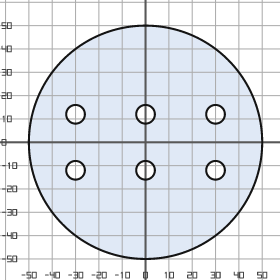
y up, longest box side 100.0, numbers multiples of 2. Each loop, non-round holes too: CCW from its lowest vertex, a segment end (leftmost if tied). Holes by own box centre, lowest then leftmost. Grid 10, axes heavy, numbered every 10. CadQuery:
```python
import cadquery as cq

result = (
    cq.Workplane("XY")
    .moveTo(0.0, 0.0)
    .circle(50.0)
    .moveTo(-30.0, -12.0)
    .circle(4.0)
    .moveTo(0.0, -12.0)
    .circle(4.0)
    .moveTo(30.0, -12.0)
    .circle(4.0)
    .moveTo(-30.0, 12.0)
    .circle(4.0)
    .moveTo(0.0, 12.0)
    .circle(4.0)
    .moveTo(30.0, 12.0)
    .circle(4.0)
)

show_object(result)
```